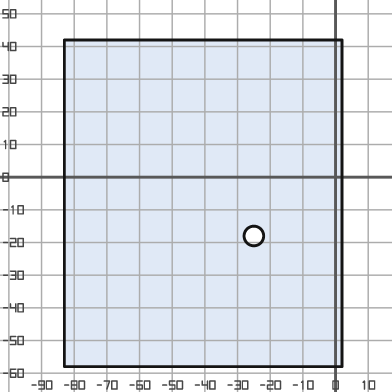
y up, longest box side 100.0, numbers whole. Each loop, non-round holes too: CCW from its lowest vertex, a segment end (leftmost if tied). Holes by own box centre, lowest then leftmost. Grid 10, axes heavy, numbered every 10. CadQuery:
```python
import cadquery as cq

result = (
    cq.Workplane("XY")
    .moveTo(-83.0, -58.0)
    .lineTo(2.0, -58.0)
    .lineTo(2.0, 42.0)
    .lineTo(-83.0, 42.0)
    .close()
    .moveTo(-25.0, -18.0)
    .circle(3.0)
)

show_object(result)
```